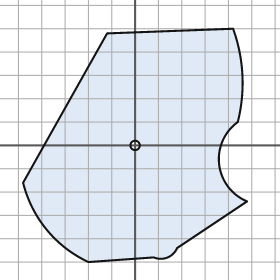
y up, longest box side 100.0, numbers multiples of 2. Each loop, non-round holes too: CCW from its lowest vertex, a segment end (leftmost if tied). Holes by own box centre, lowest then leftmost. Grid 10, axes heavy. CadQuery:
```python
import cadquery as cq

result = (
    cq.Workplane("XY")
    .moveTo(-20.0, -50.0)
    .lineTo(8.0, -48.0)
    .threePointArc((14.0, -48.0), (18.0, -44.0))
    .lineTo(48.0, -24.0)
    .threePointArc((36.0, -8.0), (44.0, 10.0))
    .threePointArc((46.0, 30.0), (42.0, 50.0))
    .lineTo(-12.0, 48.0)
    .lineTo(-48.0, -16.0)
    .threePointArc((-38.0, -36.0), (-20.0, -50.0))
    .close()
    .moveTo(0.0, 0.0)
    .circle(2.0)
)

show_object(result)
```